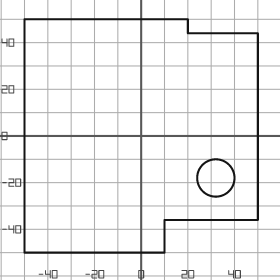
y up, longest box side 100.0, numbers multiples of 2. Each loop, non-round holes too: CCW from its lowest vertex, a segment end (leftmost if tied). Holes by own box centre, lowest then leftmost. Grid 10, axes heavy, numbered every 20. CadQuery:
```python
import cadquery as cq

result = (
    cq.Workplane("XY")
    .moveTo(-50.0, -50.0)
    .lineTo(10.0, -50.0)
    .lineTo(10.0, -36.0)
    .lineTo(50.0, -36.0)
    .lineTo(50.0, 44.0)
    .lineTo(20.0, 44.0)
    .lineTo(20.0, 50.0)
    .lineTo(-50.0, 50.0)
    .close()
    .moveTo(32.0, -18.0)
    .circle(8.0)
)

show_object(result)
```